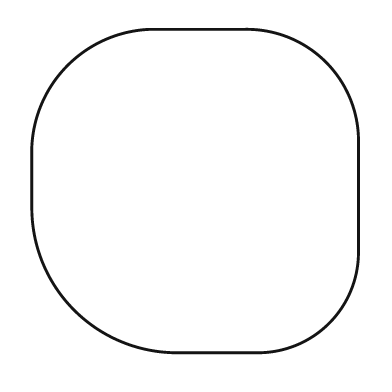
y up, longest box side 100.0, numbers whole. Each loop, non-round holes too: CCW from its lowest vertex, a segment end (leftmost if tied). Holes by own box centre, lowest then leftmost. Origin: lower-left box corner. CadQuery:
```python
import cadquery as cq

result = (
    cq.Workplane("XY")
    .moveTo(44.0, 0.0)
    .lineTo(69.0, 0.0)
    .threePointArc((91.0, 9.0), (100.0, 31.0))
    .lineTo(100.0, 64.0)
    .threePointArc((90.0, 89.0), (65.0, 99.0))
    .lineTo(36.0, 99.0)
    .threePointArc((11.0, 88.0), (0.0, 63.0))
    .lineTo(0.0, 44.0)
    .threePointArc((13.0, 13.0), (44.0, 0.0))
    .close()
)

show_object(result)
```